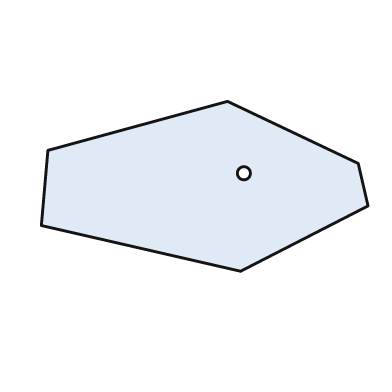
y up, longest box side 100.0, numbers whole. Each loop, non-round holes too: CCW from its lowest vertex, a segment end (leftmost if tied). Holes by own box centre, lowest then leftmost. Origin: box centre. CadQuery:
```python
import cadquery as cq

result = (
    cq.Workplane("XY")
    .moveTo(11.0, -26.0)
    .lineTo(50.0, -6.0)
    .lineTo(47.0, 7.0)
    .lineTo(7.0, 26.0)
    .lineTo(-48.0, 11.0)
    .lineTo(-50.0, -12.0)
    .close()
    .moveTo(12.0, 4.0)
    .circle(2.0)
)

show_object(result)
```